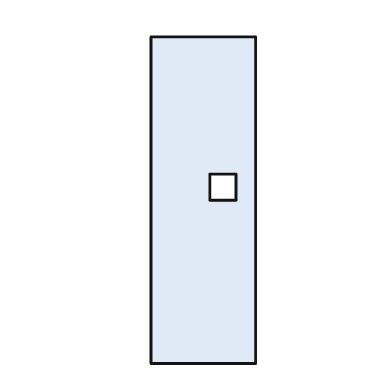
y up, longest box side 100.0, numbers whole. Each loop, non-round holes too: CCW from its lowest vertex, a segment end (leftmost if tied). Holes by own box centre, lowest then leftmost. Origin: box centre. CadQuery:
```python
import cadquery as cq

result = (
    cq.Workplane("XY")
    .moveTo(-16.0, -50.0)
    .lineTo(16.0, -50.0)
    .lineTo(16.0, 50.0)
    .lineTo(-16.0, 50.0)
    .close()
    .moveTo(2.0, 0.0)
    .lineTo(10.0, 0.0)
    .lineTo(10.0, 8.0)
    .lineTo(2.0, 8.0)
    .close()
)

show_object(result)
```